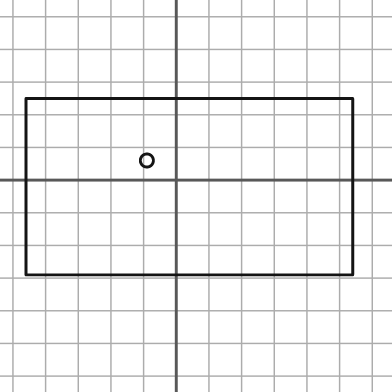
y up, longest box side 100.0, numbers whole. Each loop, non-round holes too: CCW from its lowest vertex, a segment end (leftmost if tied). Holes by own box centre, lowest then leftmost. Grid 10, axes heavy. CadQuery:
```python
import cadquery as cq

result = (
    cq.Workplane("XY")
    .moveTo(-46.0, -29.0)
    .lineTo(54.0, -29.0)
    .lineTo(54.0, 25.0)
    .lineTo(-46.0, 25.0)
    .close()
    .moveTo(-9.0, 6.0)
    .circle(2.0)
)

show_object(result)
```